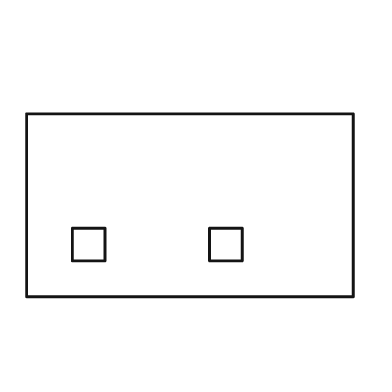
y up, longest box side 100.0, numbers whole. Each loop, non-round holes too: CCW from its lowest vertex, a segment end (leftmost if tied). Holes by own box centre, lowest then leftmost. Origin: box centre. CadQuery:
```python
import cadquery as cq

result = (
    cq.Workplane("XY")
    .moveTo(-50.0, -28.0)
    .lineTo(50.0, -28.0)
    .lineTo(50.0, 28.0)
    .lineTo(-50.0, 28.0)
    .close()
    .moveTo(-36.0, -17.0)
    .lineTo(-26.0, -17.0)
    .lineTo(-26.0, -7.0)
    .lineTo(-36.0, -7.0)
    .close()
    .moveTo(6.0, -17.0)
    .lineTo(16.0, -17.0)
    .lineTo(16.0, -7.0)
    .lineTo(6.0, -7.0)
    .close()
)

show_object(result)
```